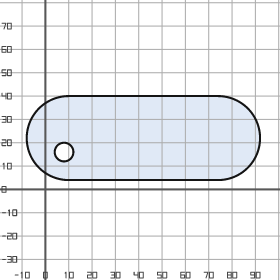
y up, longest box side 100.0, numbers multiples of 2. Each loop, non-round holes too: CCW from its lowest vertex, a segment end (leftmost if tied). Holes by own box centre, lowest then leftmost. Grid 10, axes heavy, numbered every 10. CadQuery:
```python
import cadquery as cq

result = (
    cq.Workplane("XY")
    .moveTo(10.0, 4.0)
    .lineTo(74.0, 4.0)
    .threePointArc((92.0, 22.0), (74.0, 40.0))
    .lineTo(10.0, 40.0)
    .threePointArc((-8.0, 22.0), (10.0, 4.0))
    .close()
    .moveTo(8.0, 16.0)
    .circle(4.0)
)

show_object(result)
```